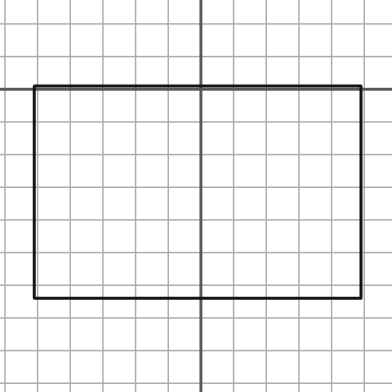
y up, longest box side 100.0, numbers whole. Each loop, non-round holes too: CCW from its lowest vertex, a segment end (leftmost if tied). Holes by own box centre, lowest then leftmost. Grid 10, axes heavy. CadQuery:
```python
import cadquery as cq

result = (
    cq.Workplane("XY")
    .moveTo(-51.0, -64.0)
    .lineTo(49.0, -64.0)
    .lineTo(49.0, 1.0)
    .lineTo(-51.0, 1.0)
    .close()
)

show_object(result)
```